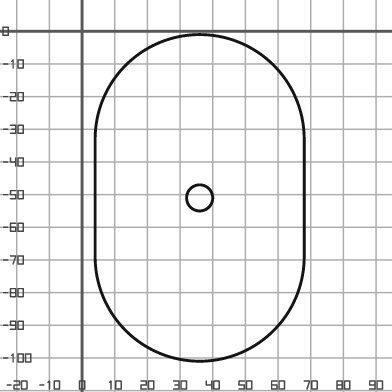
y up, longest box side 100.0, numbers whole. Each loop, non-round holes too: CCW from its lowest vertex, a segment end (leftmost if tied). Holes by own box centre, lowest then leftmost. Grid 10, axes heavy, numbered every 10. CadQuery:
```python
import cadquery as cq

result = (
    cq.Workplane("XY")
    .moveTo(4.0, -69.0)
    .threePointArc((36.0, -101.0), (68.0, -69.0))
    .lineTo(68.0, -33.0)
    .threePointArc((36.0, -1.0), (4.0, -33.0))
    .close()
    .moveTo(36.0, -51.0)
    .circle(4.0)
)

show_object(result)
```